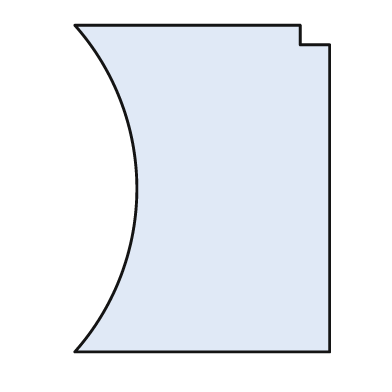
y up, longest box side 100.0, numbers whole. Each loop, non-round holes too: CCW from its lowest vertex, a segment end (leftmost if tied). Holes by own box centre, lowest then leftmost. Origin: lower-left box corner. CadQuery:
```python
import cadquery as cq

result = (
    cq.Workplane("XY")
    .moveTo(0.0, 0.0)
    .lineTo(78.0, 0.0)
    .lineTo(78.0, 94.0)
    .lineTo(69.0, 94.0)
    .lineTo(69.0, 100.0)
    .lineTo(0.0, 100.0)
    .threePointArc((19.0, 50.0), (0.0, 0.0))
    .close()
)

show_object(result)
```